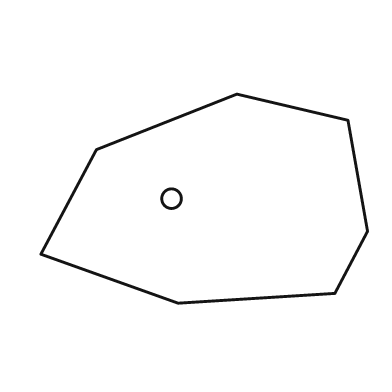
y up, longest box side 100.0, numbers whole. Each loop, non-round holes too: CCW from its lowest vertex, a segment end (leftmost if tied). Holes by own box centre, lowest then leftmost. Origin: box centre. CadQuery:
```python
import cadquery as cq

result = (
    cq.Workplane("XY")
    .moveTo(-8.0, -32.0)
    .lineTo(40.0, -29.0)
    .lineTo(50.0, -10.0)
    .lineTo(44.0, 24.0)
    .lineTo(10.0, 32.0)
    .lineTo(-33.0, 15.0)
    .lineTo(-50.0, -17.0)
    .close()
    .moveTo(-10.0, 0.0)
    .circle(3.0)
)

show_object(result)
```